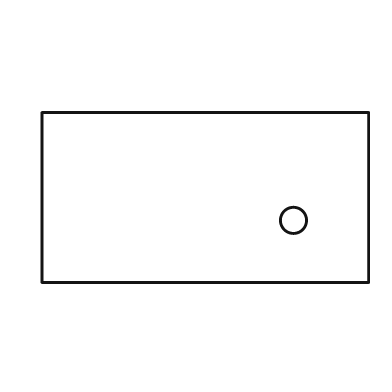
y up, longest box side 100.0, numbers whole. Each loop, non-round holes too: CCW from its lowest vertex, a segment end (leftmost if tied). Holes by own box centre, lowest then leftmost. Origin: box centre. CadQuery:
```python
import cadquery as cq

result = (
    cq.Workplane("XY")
    .moveTo(-50.0, -26.0)
    .lineTo(50.0, -26.0)
    .lineTo(50.0, 26.0)
    .lineTo(-50.0, 26.0)
    .close()
    .moveTo(27.0, -7.0)
    .circle(4.0)
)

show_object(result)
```